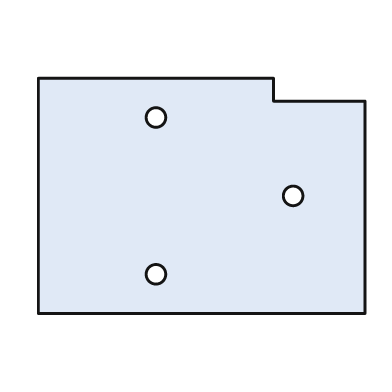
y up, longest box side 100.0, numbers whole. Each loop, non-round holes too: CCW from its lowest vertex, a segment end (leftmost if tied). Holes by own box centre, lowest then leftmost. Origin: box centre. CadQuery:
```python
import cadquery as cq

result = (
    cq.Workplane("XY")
    .moveTo(-50.0, -36.0)
    .lineTo(50.0, -36.0)
    .lineTo(50.0, 29.0)
    .lineTo(22.0, 29.0)
    .lineTo(22.0, 36.0)
    .lineTo(-50.0, 36.0)
    .close()
    .moveTo(-14.0, -24.0)
    .circle(3.0)
    .moveTo(28.0, 0.0)
    .circle(3.0)
    .moveTo(-14.0, 24.0)
    .circle(3.0)
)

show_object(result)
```